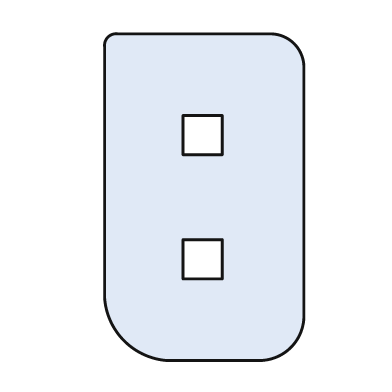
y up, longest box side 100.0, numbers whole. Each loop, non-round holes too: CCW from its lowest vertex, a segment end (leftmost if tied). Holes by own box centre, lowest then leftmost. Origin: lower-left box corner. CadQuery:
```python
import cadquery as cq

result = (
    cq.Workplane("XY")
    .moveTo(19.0, 0.0)
    .lineTo(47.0, 0.0)
    .threePointArc((57.0, 4.0), (61.0, 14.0))
    .lineTo(61.0, 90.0)
    .threePointArc((58.0, 97.0), (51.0, 100.0))
    .lineTo(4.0, 100.0)
    .threePointArc((1.0, 99.0), (0.0, 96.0))
    .lineTo(0.0, 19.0)
    .threePointArc((6.0, 6.0), (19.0, 0.0))
    .close()
    .moveTo(24.0, 25.0)
    .lineTo(36.0, 25.0)
    .lineTo(36.0, 37.0)
    .lineTo(24.0, 37.0)
    .close()
    .moveTo(24.0, 63.0)
    .lineTo(36.0, 63.0)
    .lineTo(36.0, 75.0)
    .lineTo(24.0, 75.0)
    .close()
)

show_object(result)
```